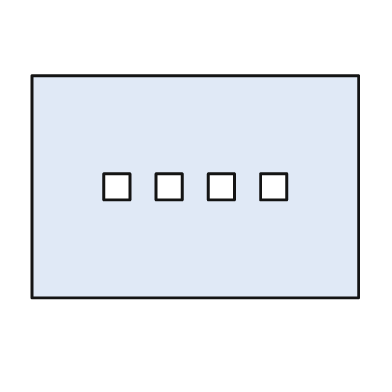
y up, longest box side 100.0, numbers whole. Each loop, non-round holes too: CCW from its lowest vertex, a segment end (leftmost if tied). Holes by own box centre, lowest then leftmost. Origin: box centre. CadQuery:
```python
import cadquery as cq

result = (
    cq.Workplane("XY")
    .moveTo(-50.0, -34.0)
    .lineTo(50.0, -34.0)
    .lineTo(50.0, 34.0)
    .lineTo(-50.0, 34.0)
    .close()
    .moveTo(-28.0, -4.0)
    .lineTo(-20.0, -4.0)
    .lineTo(-20.0, 4.0)
    .lineTo(-28.0, 4.0)
    .close()
    .moveTo(-12.0, -4.0)
    .lineTo(-4.0, -4.0)
    .lineTo(-4.0, 4.0)
    .lineTo(-12.0, 4.0)
    .close()
    .moveTo(4.0, -4.0)
    .lineTo(12.0, -4.0)
    .lineTo(12.0, 4.0)
    .lineTo(4.0, 4.0)
    .close()
    .moveTo(20.0, -4.0)
    .lineTo(28.0, -4.0)
    .lineTo(28.0, 4.0)
    .lineTo(20.0, 4.0)
    .close()
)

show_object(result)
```